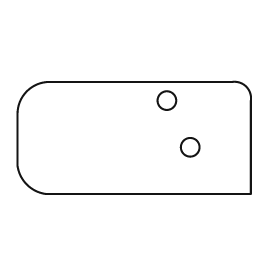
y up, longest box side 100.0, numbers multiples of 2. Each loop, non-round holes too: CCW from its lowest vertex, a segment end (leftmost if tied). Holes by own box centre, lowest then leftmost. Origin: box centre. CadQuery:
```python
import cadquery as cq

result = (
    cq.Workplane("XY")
    .moveTo(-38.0, -24.0)
    .lineTo(50.0, -24.0)
    .lineTo(50.0, 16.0)
    .threePointArc((48.0, 22.0), (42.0, 24.0))
    .lineTo(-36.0, 24.0)
    .threePointArc((-46.0, 20.0), (-50.0, 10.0))
    .lineTo(-50.0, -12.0)
    .threePointArc((-46.0, -20.0), (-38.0, -24.0))
    .close()
    .moveTo(24.0, -4.0)
    .circle(4.0)
    .moveTo(14.0, 16.0)
    .circle(4.0)
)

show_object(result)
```